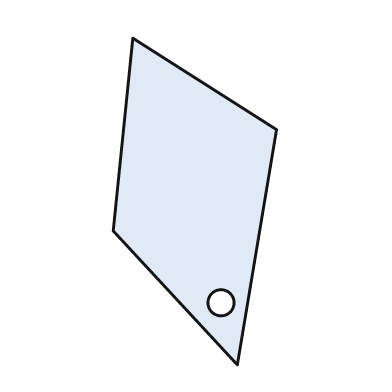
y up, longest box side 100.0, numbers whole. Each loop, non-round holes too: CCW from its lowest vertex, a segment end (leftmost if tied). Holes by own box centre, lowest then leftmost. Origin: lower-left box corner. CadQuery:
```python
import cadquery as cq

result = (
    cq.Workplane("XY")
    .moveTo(38.0, 0.0)
    .lineTo(50.0, 72.0)
    .lineTo(6.0, 100.0)
    .lineTo(0.0, 41.0)
    .close()
    .moveTo(33.0, 19.0)
    .circle(4.0)
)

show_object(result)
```